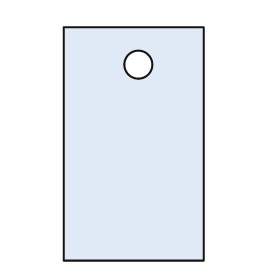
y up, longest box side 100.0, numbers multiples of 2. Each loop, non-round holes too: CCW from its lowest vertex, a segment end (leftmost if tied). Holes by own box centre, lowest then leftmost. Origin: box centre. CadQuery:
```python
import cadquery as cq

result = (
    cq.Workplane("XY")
    .moveTo(-30.0, -50.0)
    .lineTo(30.0, -50.0)
    .lineTo(30.0, 50.0)
    .lineTo(-30.0, 50.0)
    .close()
    .moveTo(2.0, 34.0)
    .circle(6.0)
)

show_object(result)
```